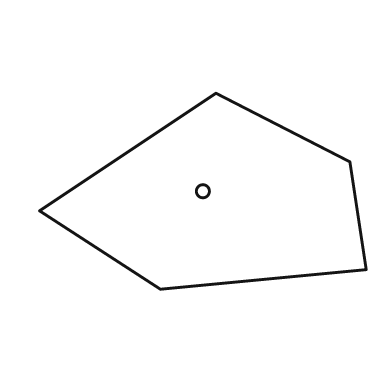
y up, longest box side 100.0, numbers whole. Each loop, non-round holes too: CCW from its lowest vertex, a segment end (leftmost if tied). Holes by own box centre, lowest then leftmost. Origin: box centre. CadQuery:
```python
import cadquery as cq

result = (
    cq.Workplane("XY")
    .moveTo(-13.0, -30.0)
    .lineTo(50.0, -24.0)
    .lineTo(45.0, 9.0)
    .lineTo(4.0, 30.0)
    .lineTo(-50.0, -6.0)
    .close()
    .moveTo(0.0, 0.0)
    .circle(2.0)
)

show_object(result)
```